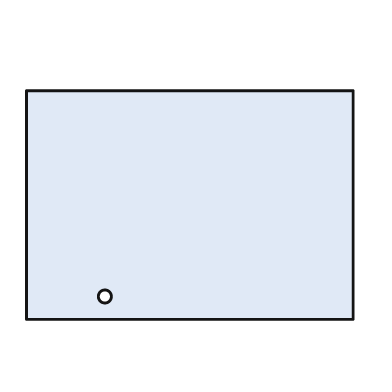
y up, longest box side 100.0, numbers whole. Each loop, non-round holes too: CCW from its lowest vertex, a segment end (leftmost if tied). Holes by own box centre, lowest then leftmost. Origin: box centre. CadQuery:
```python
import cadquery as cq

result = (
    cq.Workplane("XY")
    .moveTo(-50.0, -35.0)
    .lineTo(50.0, -35.0)
    .lineTo(50.0, 35.0)
    .lineTo(-50.0, 35.0)
    .close()
    .moveTo(-26.0, -28.0)
    .circle(2.0)
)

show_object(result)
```